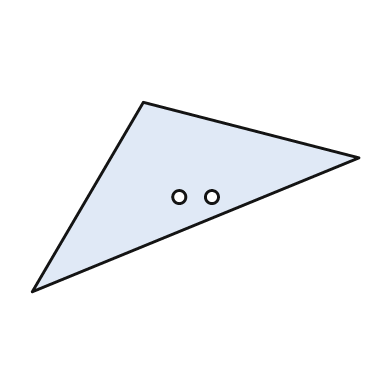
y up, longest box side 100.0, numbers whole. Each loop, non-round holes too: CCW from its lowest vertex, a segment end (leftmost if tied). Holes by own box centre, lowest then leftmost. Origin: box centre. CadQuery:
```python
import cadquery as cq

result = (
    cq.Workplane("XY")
    .moveTo(-50.0, -29.0)
    .lineTo(50.0, 12.0)
    .lineTo(-16.0, 29.0)
    .close()
    .moveTo(-5.0, 0.0)
    .circle(2.0)
    .moveTo(5.0, 0.0)
    .circle(2.0)
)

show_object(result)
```